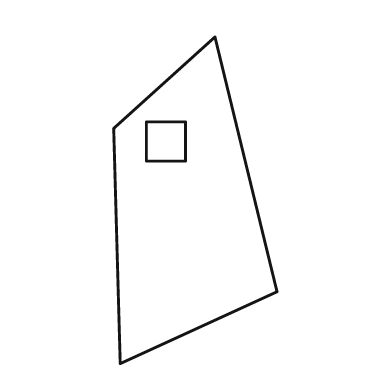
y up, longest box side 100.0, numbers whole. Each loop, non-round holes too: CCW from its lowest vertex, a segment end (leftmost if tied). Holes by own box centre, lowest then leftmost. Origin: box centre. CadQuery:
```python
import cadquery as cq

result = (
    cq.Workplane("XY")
    .moveTo(-23.0, -50.0)
    .lineTo(25.0, -28.0)
    .lineTo(6.0, 50.0)
    .lineTo(-25.0, 22.0)
    .close()
    .moveTo(-15.0, 12.0)
    .lineTo(-3.0, 12.0)
    .lineTo(-3.0, 24.0)
    .lineTo(-15.0, 24.0)
    .close()
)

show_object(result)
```